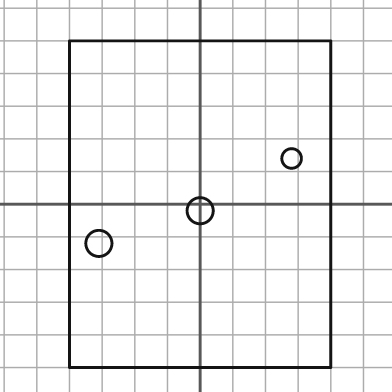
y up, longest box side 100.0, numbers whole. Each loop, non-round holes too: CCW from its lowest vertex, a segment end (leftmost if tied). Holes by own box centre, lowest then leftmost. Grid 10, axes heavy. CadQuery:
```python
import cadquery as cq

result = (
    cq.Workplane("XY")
    .moveTo(-40.0, -50.0)
    .lineTo(40.0, -50.0)
    .lineTo(40.0, 50.0)
    .lineTo(-40.0, 50.0)
    .close()
    .moveTo(-31.0, -12.0)
    .circle(4.0)
    .moveTo(0.0, -2.0)
    .circle(4.0)
    .moveTo(28.0, 14.0)
    .circle(3.0)
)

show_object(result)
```